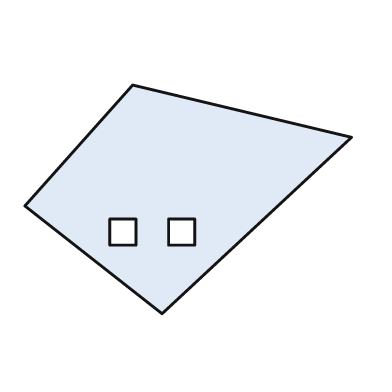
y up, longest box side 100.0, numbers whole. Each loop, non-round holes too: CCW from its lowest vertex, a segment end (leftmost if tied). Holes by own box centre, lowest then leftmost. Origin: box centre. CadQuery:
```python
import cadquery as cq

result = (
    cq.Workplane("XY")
    .moveTo(-8.0, -35.0)
    .lineTo(50.0, 19.0)
    .lineTo(-17.0, 35.0)
    .lineTo(-50.0, -2.0)
    .close()
    .moveTo(-24.0, -14.0)
    .lineTo(-16.0, -14.0)
    .lineTo(-16.0, -6.0)
    .lineTo(-24.0, -6.0)
    .close()
    .moveTo(-6.0, -14.0)
    .lineTo(2.0, -14.0)
    .lineTo(2.0, -6.0)
    .lineTo(-6.0, -6.0)
    .close()
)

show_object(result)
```